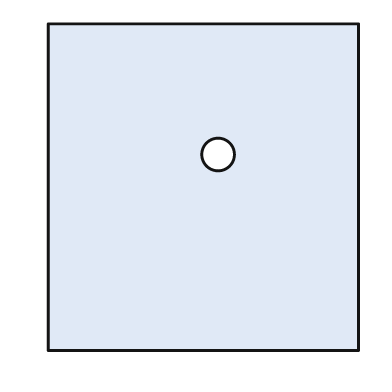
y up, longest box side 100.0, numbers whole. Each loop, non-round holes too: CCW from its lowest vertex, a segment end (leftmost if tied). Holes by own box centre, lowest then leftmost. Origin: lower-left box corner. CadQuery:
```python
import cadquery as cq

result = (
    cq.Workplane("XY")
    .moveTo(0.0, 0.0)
    .lineTo(95.0, 0.0)
    .lineTo(95.0, 100.0)
    .lineTo(0.0, 100.0)
    .close()
    .moveTo(52.0, 60.0)
    .circle(5.0)
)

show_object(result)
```